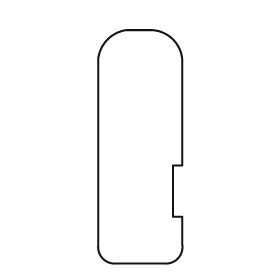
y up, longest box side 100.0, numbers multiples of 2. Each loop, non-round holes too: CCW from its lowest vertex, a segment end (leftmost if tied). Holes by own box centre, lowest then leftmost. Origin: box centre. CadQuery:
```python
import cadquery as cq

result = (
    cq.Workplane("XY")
    .moveTo(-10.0, -50.0)
    .lineTo(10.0, -50.0)
    .threePointArc((16.0, -48.0), (18.0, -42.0))
    .lineTo(18.0, -30.0)
    .lineTo(14.0, -30.0)
    .lineTo(14.0, -8.0)
    .lineTo(18.0, -8.0)
    .lineTo(18.0, 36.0)
    .threePointArc((14.0, 46.0), (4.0, 50.0))
    .lineTo(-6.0, 50.0)
    .threePointArc((-14.0, 46.0), (-18.0, 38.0))
    .lineTo(-18.0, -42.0)
    .threePointArc((-16.0, -48.0), (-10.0, -50.0))
    .close()
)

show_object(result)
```